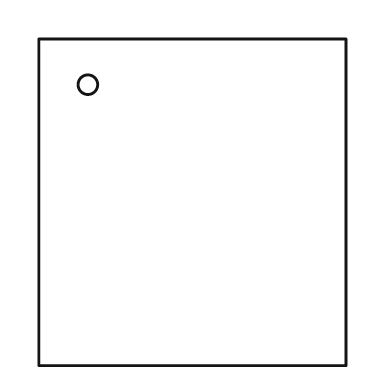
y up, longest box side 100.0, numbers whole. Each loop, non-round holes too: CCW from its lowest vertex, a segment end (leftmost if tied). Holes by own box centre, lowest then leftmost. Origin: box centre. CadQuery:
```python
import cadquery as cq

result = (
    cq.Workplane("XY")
    .moveTo(-47.0, -50.0)
    .lineTo(47.0, -50.0)
    .lineTo(47.0, 50.0)
    .lineTo(-47.0, 50.0)
    .close()
    .moveTo(-32.0, 36.0)
    .circle(3.0)
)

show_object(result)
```